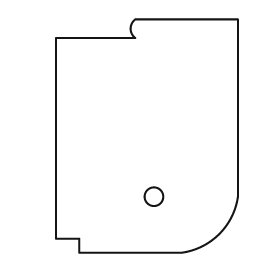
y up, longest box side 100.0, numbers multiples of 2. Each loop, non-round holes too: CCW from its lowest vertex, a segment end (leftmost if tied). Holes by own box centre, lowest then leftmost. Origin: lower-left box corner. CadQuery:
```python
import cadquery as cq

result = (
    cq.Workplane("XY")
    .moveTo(10.0, 0.0)
    .lineTo(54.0, 0.0)
    .threePointArc((70.0, 8.0), (78.0, 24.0))
    .lineTo(78.0, 100.0)
    .lineTo(34.0, 100.0)
    .threePointArc((32.0, 96.0), (34.0, 92.0))
    .lineTo(0.0, 92.0)
    .lineTo(0.0, 6.0)
    .lineTo(10.0, 6.0)
    .close()
    .moveTo(42.0, 24.0)
    .circle(4.0)
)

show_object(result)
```